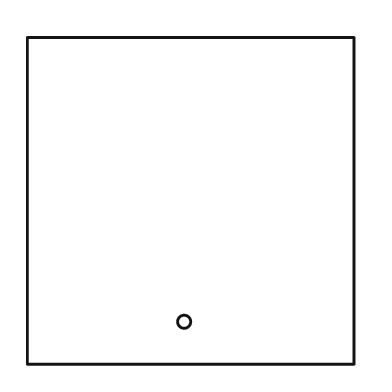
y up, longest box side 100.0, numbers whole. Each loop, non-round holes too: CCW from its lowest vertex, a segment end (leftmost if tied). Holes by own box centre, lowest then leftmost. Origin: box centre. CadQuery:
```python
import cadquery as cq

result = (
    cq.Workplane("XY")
    .moveTo(-50.0, -50.0)
    .lineTo(50.0, -50.0)
    .lineTo(50.0, 50.0)
    .lineTo(-50.0, 50.0)
    .close()
    .moveTo(-2.0, -37.0)
    .circle(2.0)
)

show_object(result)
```